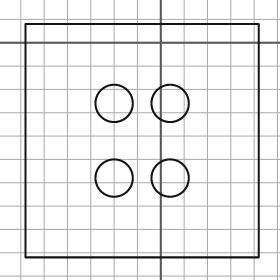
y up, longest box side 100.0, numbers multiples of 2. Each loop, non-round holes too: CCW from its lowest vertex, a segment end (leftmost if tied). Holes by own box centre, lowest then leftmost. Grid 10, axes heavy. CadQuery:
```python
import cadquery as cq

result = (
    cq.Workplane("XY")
    .moveTo(-58.0, -92.0)
    .lineTo(42.0, -92.0)
    .lineTo(42.0, 8.0)
    .lineTo(-58.0, 8.0)
    .close()
    .moveTo(-20.0, -58.0)
    .circle(8.0)
    .moveTo(4.0, -58.0)
    .circle(8.0)
    .moveTo(-20.0, -26.0)
    .circle(8.0)
    .moveTo(4.0, -26.0)
    .circle(8.0)
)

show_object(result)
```